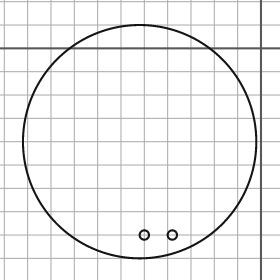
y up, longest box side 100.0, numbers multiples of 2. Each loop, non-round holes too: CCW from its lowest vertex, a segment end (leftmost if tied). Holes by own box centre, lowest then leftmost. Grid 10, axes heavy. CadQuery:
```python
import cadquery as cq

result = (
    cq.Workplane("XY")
    .moveTo(-52.0, -40.0)
    .circle(50.0)
    .moveTo(-50.0, -80.0)
    .circle(2.0)
    .moveTo(-38.0, -80.0)
    .circle(2.0)
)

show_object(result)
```